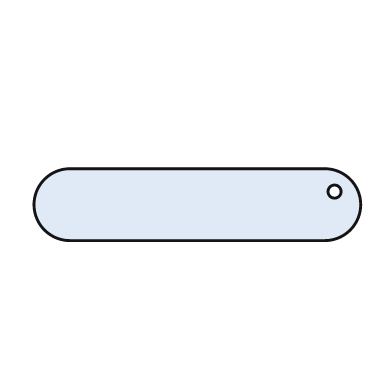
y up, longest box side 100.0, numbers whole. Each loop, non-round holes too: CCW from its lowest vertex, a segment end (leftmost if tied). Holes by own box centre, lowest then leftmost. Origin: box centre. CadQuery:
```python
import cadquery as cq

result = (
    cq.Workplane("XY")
    .moveTo(-39.0, -11.0)
    .lineTo(39.0, -11.0)
    .threePointArc((50.0, 0.0), (39.0, 11.0))
    .lineTo(-39.0, 11.0)
    .threePointArc((-50.0, 0.0), (-39.0, -11.0))
    .close()
    .moveTo(42.0, 4.0)
    .circle(2.0)
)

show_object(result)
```